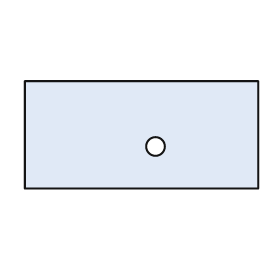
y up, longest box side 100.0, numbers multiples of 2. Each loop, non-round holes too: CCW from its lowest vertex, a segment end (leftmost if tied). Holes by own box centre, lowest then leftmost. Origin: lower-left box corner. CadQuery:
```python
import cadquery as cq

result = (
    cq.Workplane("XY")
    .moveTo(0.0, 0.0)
    .lineTo(100.0, 0.0)
    .lineTo(100.0, 46.0)
    .lineTo(0.0, 46.0)
    .close()
    .moveTo(56.0, 18.0)
    .circle(4.0)
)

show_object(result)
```